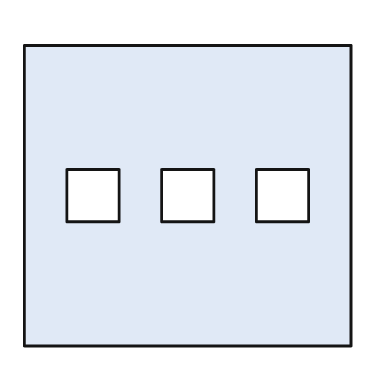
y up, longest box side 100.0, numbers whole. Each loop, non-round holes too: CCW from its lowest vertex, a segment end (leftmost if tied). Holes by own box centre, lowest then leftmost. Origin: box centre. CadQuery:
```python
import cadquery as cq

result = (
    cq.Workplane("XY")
    .moveTo(-50.0, -46.0)
    .lineTo(50.0, -46.0)
    .lineTo(50.0, 46.0)
    .lineTo(-50.0, 46.0)
    .close()
    .moveTo(-37.0, -8.0)
    .lineTo(-21.0, -8.0)
    .lineTo(-21.0, 8.0)
    .lineTo(-37.0, 8.0)
    .close()
    .moveTo(-8.0, -8.0)
    .lineTo(8.0, -8.0)
    .lineTo(8.0, 8.0)
    .lineTo(-8.0, 8.0)
    .close()
    .moveTo(21.0, -8.0)
    .lineTo(37.0, -8.0)
    .lineTo(37.0, 8.0)
    .lineTo(21.0, 8.0)
    .close()
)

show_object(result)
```